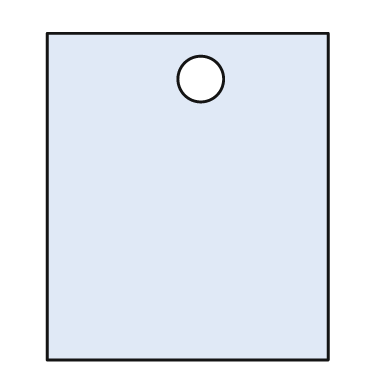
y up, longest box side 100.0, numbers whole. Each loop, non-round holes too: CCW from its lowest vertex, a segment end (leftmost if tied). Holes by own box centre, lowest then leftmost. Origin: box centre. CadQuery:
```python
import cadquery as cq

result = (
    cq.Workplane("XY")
    .moveTo(-43.0, -50.0)
    .lineTo(43.0, -50.0)
    .lineTo(43.0, 50.0)
    .lineTo(-43.0, 50.0)
    .close()
    .moveTo(4.0, 36.0)
    .circle(7.0)
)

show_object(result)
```